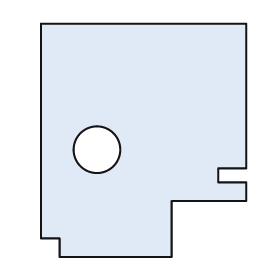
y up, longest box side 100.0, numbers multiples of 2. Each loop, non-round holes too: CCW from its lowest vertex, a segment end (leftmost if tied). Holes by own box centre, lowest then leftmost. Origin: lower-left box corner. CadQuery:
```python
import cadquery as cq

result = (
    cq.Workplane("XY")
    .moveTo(8.0, 0.0)
    .lineTo(56.0, 0.0)
    .lineTo(56.0, 24.0)
    .lineTo(88.0, 24.0)
    .lineTo(88.0, 32.0)
    .lineTo(76.0, 32.0)
    .lineTo(76.0, 38.0)
    .lineTo(88.0, 38.0)
    .lineTo(88.0, 100.0)
    .lineTo(0.0, 100.0)
    .lineTo(0.0, 8.0)
    .lineTo(8.0, 8.0)
    .close()
    .moveTo(24.0, 46.0)
    .circle(10.0)
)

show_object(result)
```